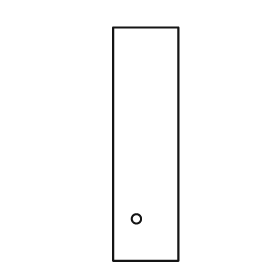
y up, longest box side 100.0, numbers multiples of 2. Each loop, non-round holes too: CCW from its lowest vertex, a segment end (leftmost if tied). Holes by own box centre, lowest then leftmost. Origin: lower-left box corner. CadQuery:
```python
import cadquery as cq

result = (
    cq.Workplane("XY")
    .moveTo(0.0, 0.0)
    .lineTo(28.0, 0.0)
    .lineTo(28.0, 100.0)
    .lineTo(0.0, 100.0)
    .close()
    .moveTo(10.0, 18.0)
    .circle(2.0)
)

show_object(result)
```